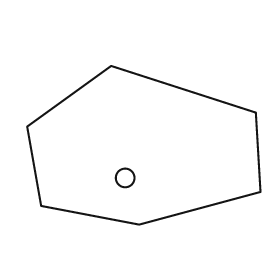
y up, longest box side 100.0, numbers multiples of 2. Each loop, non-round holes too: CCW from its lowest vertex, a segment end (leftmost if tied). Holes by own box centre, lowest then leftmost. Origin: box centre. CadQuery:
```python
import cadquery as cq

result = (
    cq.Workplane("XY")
    .moveTo(-2.0, -34.0)
    .lineTo(50.0, -20.0)
    .lineTo(48.0, 14.0)
    .lineTo(-14.0, 34.0)
    .lineTo(-50.0, 8.0)
    .lineTo(-44.0, -26.0)
    .close()
    .moveTo(-8.0, -14.0)
    .circle(4.0)
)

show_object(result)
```